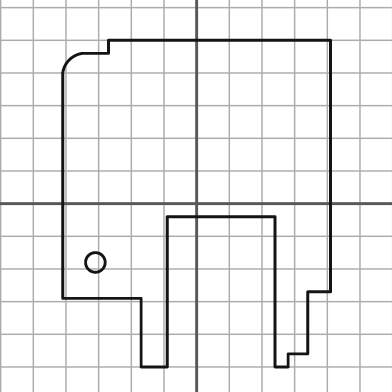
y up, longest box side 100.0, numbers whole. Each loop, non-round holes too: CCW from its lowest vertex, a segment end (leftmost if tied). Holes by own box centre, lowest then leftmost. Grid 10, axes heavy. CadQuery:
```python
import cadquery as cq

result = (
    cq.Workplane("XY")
    .moveTo(-17.0, -50.0)
    .lineTo(-9.0, -50.0)
    .lineTo(-9.0, -4.0)
    .lineTo(24.0, -4.0)
    .lineTo(24.0, -50.0)
    .lineTo(28.0, -50.0)
    .lineTo(28.0, -46.0)
    .lineTo(34.0, -46.0)
    .lineTo(34.0, -27.0)
    .lineTo(41.0, -27.0)
    .lineTo(41.0, 50.0)
    .lineTo(-27.0, 50.0)
    .lineTo(-27.0, 46.0)
    .lineTo(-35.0, 46.0)
    .threePointArc((-39.0, 44.0), (-41.0, 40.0))
    .lineTo(-41.0, -29.0)
    .lineTo(-17.0, -29.0)
    .close()
    .moveTo(-31.0, -18.0)
    .circle(3.0)
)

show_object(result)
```